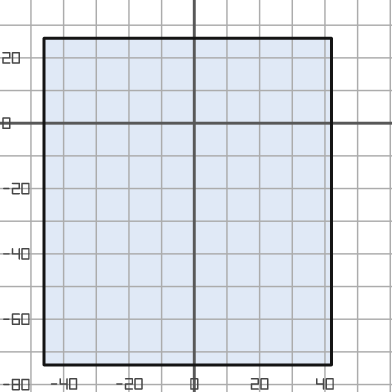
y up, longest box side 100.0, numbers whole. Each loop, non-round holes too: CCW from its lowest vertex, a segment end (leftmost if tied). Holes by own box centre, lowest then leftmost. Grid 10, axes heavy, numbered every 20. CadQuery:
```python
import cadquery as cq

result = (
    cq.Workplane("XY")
    .moveTo(-46.0, -74.0)
    .lineTo(42.0, -74.0)
    .lineTo(42.0, 26.0)
    .lineTo(-46.0, 26.0)
    .close()
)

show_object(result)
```